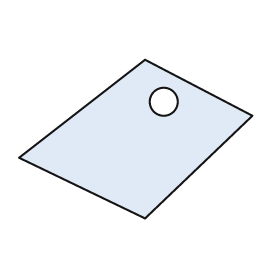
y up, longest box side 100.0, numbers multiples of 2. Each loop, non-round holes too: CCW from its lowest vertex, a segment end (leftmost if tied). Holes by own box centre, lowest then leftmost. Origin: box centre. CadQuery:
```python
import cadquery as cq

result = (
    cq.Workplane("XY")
    .moveTo(4.0, -34.0)
    .lineTo(50.0, 10.0)
    .lineTo(4.0, 34.0)
    .lineTo(-50.0, -8.0)
    .close()
    .moveTo(12.0, 16.0)
    .circle(6.0)
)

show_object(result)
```